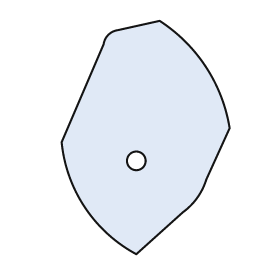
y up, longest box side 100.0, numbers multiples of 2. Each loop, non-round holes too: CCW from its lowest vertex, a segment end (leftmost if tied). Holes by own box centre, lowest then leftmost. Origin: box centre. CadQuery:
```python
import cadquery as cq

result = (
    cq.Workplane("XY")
    .moveTo(-4.0, -50.0)
    .lineTo(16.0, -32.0)
    .threePointArc((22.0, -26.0), (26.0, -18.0))
    .lineTo(36.0, 4.0)
    .threePointArc((26.0, 30.0), (6.0, 50.0))
    .lineTo(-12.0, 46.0)
    .threePointArc((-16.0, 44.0), (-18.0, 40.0))
    .lineTo(-36.0, -2.0)
    .threePointArc((-26.0, -30.0), (-4.0, -50.0))
    .close()
    .moveTo(-4.0, -10.0)
    .circle(4.0)
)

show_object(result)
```